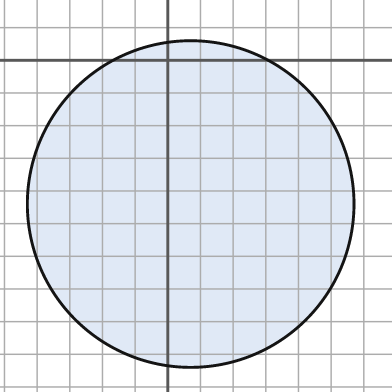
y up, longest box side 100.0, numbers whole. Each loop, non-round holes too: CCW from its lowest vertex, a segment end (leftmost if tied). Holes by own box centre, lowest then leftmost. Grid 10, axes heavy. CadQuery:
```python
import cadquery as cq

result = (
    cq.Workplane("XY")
    .moveTo(7.0, -44.0)
    .circle(50.0)
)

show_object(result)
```